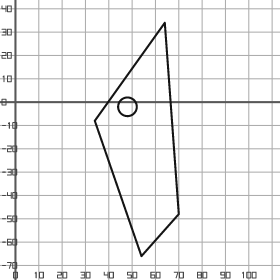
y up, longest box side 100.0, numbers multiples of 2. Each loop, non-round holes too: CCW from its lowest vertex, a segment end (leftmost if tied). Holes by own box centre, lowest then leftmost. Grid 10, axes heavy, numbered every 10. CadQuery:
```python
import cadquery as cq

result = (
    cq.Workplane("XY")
    .moveTo(54.0, -66.0)
    .lineTo(70.0, -48.0)
    .lineTo(64.0, 34.0)
    .lineTo(34.0, -8.0)
    .close()
    .moveTo(48.0, -2.0)
    .circle(4.0)
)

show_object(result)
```